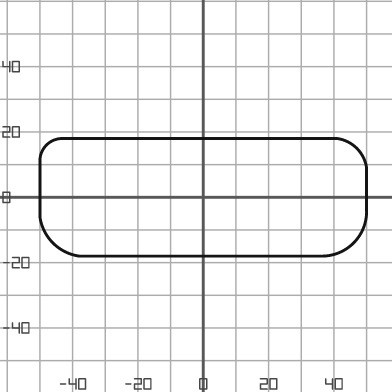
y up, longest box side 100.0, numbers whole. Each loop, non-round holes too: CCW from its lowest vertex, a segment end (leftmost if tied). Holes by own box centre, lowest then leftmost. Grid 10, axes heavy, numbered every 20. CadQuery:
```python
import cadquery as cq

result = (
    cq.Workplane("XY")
    .moveTo(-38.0, -18.0)
    .lineTo(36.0, -18.0)
    .threePointArc((46.0, -14.0), (50.0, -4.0))
    .lineTo(50.0, 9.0)
    .threePointArc((47.0, 15.0), (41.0, 18.0))
    .lineTo(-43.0, 18.0)
    .threePointArc((-48.0, 16.0), (-50.0, 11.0))
    .lineTo(-50.0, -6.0)
    .threePointArc((-46.0, -14.0), (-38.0, -18.0))
    .close()
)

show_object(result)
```